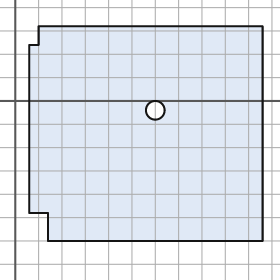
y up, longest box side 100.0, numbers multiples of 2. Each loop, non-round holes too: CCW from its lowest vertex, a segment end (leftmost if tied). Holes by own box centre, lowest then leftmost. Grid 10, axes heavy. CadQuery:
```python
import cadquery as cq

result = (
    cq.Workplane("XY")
    .moveTo(14.0, -60.0)
    .lineTo(106.0, -60.0)
    .lineTo(106.0, 32.0)
    .lineTo(10.0, 32.0)
    .lineTo(10.0, 24.0)
    .lineTo(6.0, 24.0)
    .lineTo(6.0, -48.0)
    .lineTo(14.0, -48.0)
    .close()
    .moveTo(60.0, -4.0)
    .circle(4.0)
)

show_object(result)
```